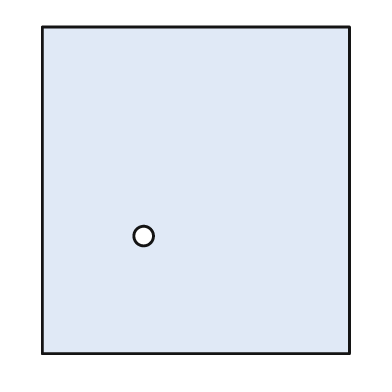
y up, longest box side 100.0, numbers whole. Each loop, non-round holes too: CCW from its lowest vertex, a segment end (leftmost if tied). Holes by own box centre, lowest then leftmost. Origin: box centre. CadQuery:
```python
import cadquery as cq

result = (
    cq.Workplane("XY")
    .moveTo(-47.0, -50.0)
    .lineTo(47.0, -50.0)
    .lineTo(47.0, 50.0)
    .lineTo(-47.0, 50.0)
    .close()
    .moveTo(-16.0, -14.0)
    .circle(3.0)
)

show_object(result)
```